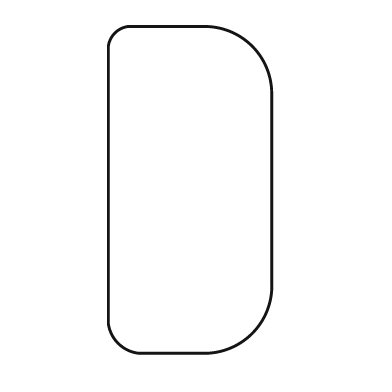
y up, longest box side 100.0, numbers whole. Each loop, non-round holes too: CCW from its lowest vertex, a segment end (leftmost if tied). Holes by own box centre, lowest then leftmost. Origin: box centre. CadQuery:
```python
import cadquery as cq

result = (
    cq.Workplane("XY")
    .moveTo(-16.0, -50.0)
    .lineTo(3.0, -50.0)
    .threePointArc((19.0, -44.0), (25.0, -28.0))
    .lineTo(25.0, 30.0)
    .threePointArc((19.0, 44.0), (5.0, 50.0))
    .lineTo(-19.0, 50.0)
    .threePointArc((-23.0, 48.0), (-25.0, 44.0))
    .lineTo(-25.0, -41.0)
    .threePointArc((-22.0, -47.0), (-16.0, -50.0))
    .close()
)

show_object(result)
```